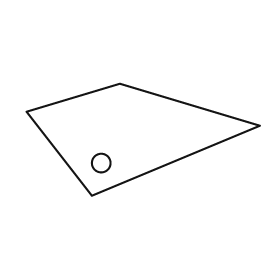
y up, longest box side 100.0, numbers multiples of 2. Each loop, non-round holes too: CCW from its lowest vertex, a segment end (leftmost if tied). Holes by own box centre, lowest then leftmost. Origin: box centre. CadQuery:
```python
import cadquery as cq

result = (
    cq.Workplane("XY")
    .moveTo(-22.0, -24.0)
    .lineTo(50.0, 6.0)
    .lineTo(-10.0, 24.0)
    .lineTo(-50.0, 12.0)
    .close()
    .moveTo(-18.0, -10.0)
    .circle(4.0)
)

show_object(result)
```